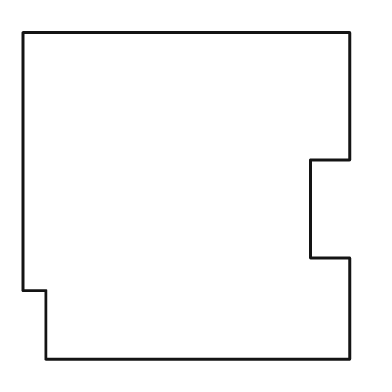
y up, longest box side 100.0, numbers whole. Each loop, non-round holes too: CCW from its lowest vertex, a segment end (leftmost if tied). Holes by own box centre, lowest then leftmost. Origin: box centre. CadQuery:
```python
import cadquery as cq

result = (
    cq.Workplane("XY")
    .moveTo(-43.0, -50.0)
    .lineTo(50.0, -50.0)
    .lineTo(50.0, -19.0)
    .lineTo(38.0, -19.0)
    .lineTo(38.0, 11.0)
    .lineTo(50.0, 11.0)
    .lineTo(50.0, 50.0)
    .lineTo(-50.0, 50.0)
    .lineTo(-50.0, -29.0)
    .lineTo(-43.0, -29.0)
    .close()
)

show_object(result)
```